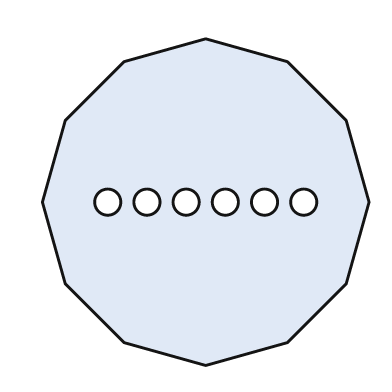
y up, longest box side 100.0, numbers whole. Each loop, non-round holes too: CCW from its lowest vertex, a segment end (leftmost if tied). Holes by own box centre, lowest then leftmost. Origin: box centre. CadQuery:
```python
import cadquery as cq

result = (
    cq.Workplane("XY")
    .moveTo(0.0, -50.0)
    .lineTo(25.0, -43.0)
    .lineTo(43.0, -25.0)
    .lineTo(50.0, 0.0)
    .lineTo(43.0, 25.0)
    .lineTo(25.0, 43.0)
    .lineTo(0.0, 50.0)
    .lineTo(-25.0, 43.0)
    .lineTo(-43.0, 25.0)
    .lineTo(-50.0, 0.0)
    .lineTo(-43.0, -25.0)
    .lineTo(-25.0, -43.0)
    .close()
    .moveTo(-30.0, 0.0)
    .circle(4.0)
    .moveTo(-18.0, 0.0)
    .circle(4.0)
    .moveTo(-6.0, 0.0)
    .circle(4.0)
    .moveTo(6.0, 0.0)
    .circle(4.0)
    .moveTo(18.0, 0.0)
    .circle(4.0)
    .moveTo(30.0, 0.0)
    .circle(4.0)
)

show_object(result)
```